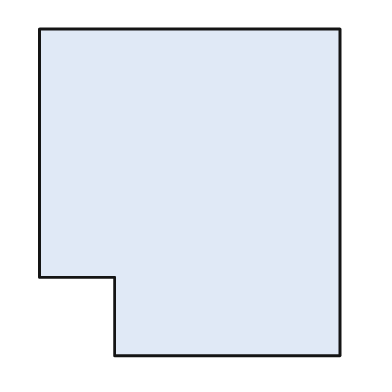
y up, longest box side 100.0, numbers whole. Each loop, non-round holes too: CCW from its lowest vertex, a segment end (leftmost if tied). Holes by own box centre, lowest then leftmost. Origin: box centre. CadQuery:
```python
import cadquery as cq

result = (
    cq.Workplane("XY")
    .moveTo(-23.0, -50.0)
    .lineTo(46.0, -50.0)
    .lineTo(46.0, 50.0)
    .lineTo(-46.0, 50.0)
    .lineTo(-46.0, -26.0)
    .lineTo(-23.0, -26.0)
    .close()
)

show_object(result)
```